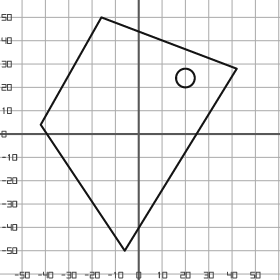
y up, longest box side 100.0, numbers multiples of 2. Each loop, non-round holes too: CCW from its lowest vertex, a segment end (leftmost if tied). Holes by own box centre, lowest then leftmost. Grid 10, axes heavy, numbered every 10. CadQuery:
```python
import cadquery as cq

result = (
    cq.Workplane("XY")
    .moveTo(-6.0, -50.0)
    .lineTo(42.0, 28.0)
    .lineTo(-16.0, 50.0)
    .lineTo(-42.0, 4.0)
    .close()
    .moveTo(20.0, 24.0)
    .circle(4.0)
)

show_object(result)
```